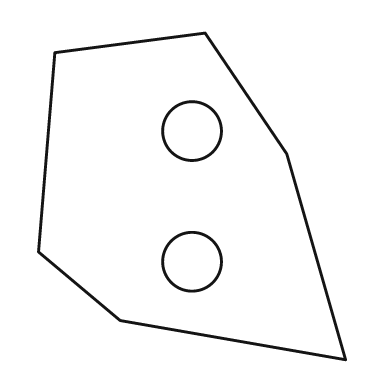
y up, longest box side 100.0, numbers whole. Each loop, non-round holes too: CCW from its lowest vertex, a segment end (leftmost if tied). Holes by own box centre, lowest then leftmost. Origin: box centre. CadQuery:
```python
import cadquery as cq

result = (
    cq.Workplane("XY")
    .moveTo(47.0, -50.0)
    .lineTo(29.0, 13.0)
    .lineTo(4.0, 50.0)
    .lineTo(-42.0, 44.0)
    .lineTo(-47.0, -17.0)
    .lineTo(-22.0, -38.0)
    .close()
    .moveTo(0.0, -20.0)
    .circle(9.0)
    .moveTo(0.0, 20.0)
    .circle(9.0)
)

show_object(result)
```